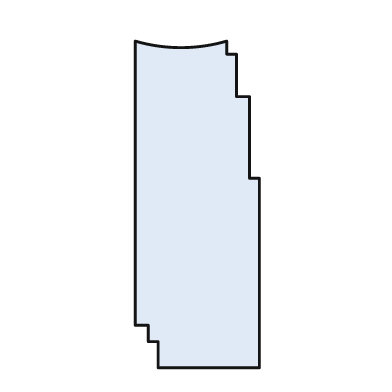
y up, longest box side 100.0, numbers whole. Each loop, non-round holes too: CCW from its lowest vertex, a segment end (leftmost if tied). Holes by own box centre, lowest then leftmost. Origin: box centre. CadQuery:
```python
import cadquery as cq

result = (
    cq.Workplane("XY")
    .moveTo(-12.0, -50.0)
    .lineTo(19.0, -50.0)
    .lineTo(19.0, 8.0)
    .lineTo(16.0, 8.0)
    .lineTo(16.0, 33.0)
    .lineTo(12.0, 33.0)
    .lineTo(12.0, 46.0)
    .lineTo(9.0, 46.0)
    .lineTo(9.0, 50.0)
    .threePointArc((-5.0, 48.0), (-19.0, 50.0))
    .lineTo(-19.0, -37.0)
    .lineTo(-15.0, -37.0)
    .lineTo(-15.0, -42.0)
    .lineTo(-12.0, -42.0)
    .close()
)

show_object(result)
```